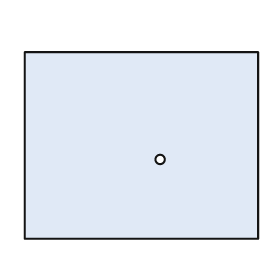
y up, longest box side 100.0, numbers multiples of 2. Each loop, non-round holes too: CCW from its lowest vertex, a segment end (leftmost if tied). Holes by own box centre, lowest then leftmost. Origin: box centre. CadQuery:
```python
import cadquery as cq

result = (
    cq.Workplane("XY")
    .moveTo(-50.0, -40.0)
    .lineTo(50.0, -40.0)
    .lineTo(50.0, 40.0)
    .lineTo(-50.0, 40.0)
    .close()
    .moveTo(8.0, -6.0)
    .circle(2.0)
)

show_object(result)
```